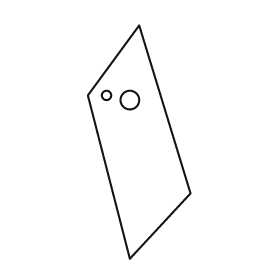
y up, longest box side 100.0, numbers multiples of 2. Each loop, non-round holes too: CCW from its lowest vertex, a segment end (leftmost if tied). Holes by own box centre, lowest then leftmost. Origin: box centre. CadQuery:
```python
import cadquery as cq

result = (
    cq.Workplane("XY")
    .moveTo(-4.0, -50.0)
    .lineTo(22.0, -22.0)
    .lineTo(0.0, 50.0)
    .lineTo(-22.0, 20.0)
    .close()
    .moveTo(-4.0, 18.0)
    .circle(4.0)
    .moveTo(-14.0, 20.0)
    .circle(2.0)
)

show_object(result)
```